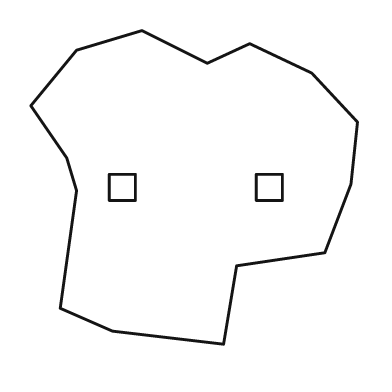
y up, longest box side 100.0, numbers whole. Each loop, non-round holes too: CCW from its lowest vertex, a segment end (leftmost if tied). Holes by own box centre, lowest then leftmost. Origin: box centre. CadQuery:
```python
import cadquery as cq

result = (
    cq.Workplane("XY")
    .moveTo(9.0, -48.0)
    .lineTo(13.0, -24.0)
    .lineTo(40.0, -20.0)
    .lineTo(48.0, 1.0)
    .lineTo(50.0, 20.0)
    .lineTo(36.0, 35.0)
    .lineTo(17.0, 44.0)
    .lineTo(4.0, 38.0)
    .lineTo(-16.0, 48.0)
    .lineTo(-36.0, 42.0)
    .lineTo(-50.0, 25.0)
    .lineTo(-39.0, 9.0)
    .lineTo(-36.0, -1.0)
    .lineTo(-41.0, -37.0)
    .lineTo(-25.0, -44.0)
    .close()
    .moveTo(-26.0, -4.0)
    .lineTo(-18.0, -4.0)
    .lineTo(-18.0, 4.0)
    .lineTo(-26.0, 4.0)
    .close()
    .moveTo(19.0, -4.0)
    .lineTo(27.0, -4.0)
    .lineTo(27.0, 4.0)
    .lineTo(19.0, 4.0)
    .close()
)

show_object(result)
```